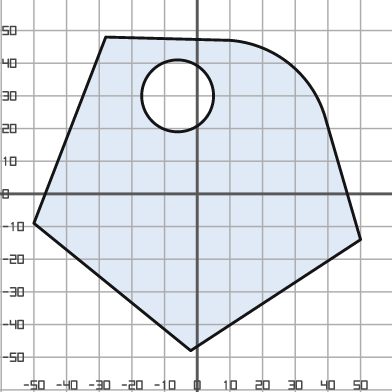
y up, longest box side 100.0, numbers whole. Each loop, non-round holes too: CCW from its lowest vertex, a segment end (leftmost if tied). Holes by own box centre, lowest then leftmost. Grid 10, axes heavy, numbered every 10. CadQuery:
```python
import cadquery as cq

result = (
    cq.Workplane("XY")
    .moveTo(-2.0, -48.0)
    .lineTo(50.0, -14.0)
    .lineTo(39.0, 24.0)
    .threePointArc((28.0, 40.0), (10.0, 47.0))
    .lineTo(-28.0, 48.0)
    .lineTo(-50.0, -9.0)
    .close()
    .moveTo(-6.0, 30.0)
    .circle(11.0)
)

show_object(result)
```